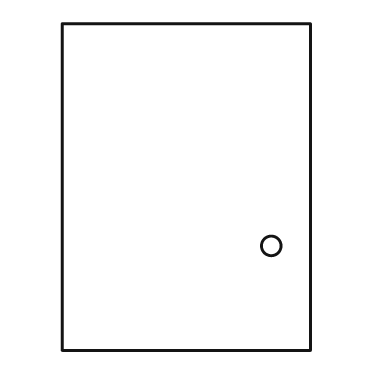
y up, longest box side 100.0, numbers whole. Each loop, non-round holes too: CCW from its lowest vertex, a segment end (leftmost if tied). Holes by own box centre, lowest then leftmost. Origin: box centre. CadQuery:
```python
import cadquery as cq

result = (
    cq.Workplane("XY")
    .moveTo(-38.0, -50.0)
    .lineTo(38.0, -50.0)
    .lineTo(38.0, 50.0)
    .lineTo(-38.0, 50.0)
    .close()
    .moveTo(26.0, -18.0)
    .circle(3.0)
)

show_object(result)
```